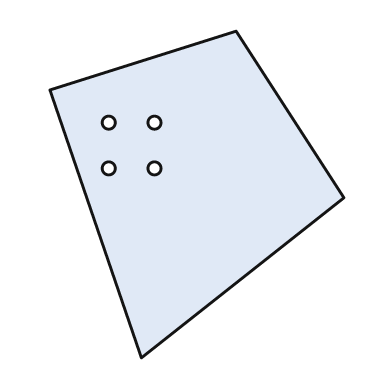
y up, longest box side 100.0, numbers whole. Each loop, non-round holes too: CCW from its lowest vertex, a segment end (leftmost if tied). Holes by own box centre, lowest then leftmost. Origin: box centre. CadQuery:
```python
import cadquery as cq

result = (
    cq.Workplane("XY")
    .moveTo(-17.0, -50.0)
    .lineTo(45.0, -1.0)
    .lineTo(12.0, 50.0)
    .lineTo(-45.0, 32.0)
    .close()
    .moveTo(-27.0, 8.0)
    .circle(2.0)
    .moveTo(-13.0, 8.0)
    .circle(2.0)
    .moveTo(-27.0, 22.0)
    .circle(2.0)
    .moveTo(-13.0, 22.0)
    .circle(2.0)
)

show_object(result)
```